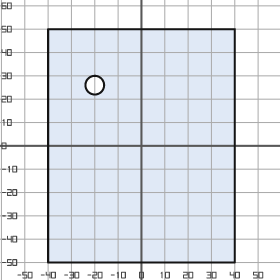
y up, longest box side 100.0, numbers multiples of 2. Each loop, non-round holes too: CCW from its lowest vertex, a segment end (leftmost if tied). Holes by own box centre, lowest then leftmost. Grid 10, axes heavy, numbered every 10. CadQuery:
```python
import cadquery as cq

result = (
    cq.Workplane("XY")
    .moveTo(-40.0, -50.0)
    .lineTo(40.0, -50.0)
    .lineTo(40.0, 50.0)
    .lineTo(-40.0, 50.0)
    .close()
    .moveTo(-20.0, 26.0)
    .circle(4.0)
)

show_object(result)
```